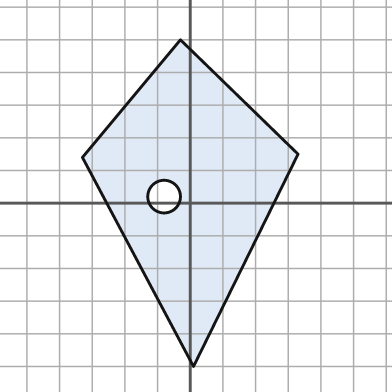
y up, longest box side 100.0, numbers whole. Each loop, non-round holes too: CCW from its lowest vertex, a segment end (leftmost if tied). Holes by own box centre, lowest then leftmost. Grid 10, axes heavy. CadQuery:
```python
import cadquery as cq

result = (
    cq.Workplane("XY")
    .moveTo(1.0, -50.0)
    .lineTo(33.0, 15.0)
    .lineTo(-3.0, 50.0)
    .lineTo(-33.0, 14.0)
    .close()
    .moveTo(-8.0, 2.0)
    .circle(5.0)
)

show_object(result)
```